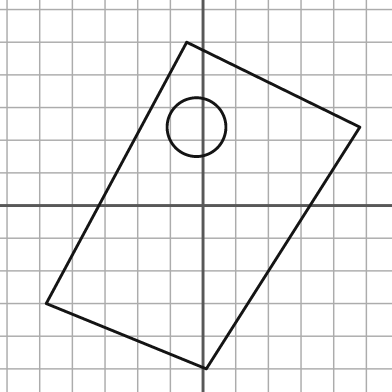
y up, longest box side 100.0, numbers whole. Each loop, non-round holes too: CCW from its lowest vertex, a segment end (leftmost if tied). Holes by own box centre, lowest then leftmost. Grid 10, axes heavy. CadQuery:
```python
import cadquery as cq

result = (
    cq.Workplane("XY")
    .moveTo(1.0, -50.0)
    .lineTo(48.0, 24.0)
    .lineTo(-5.0, 50.0)
    .lineTo(-48.0, -30.0)
    .close()
    .moveTo(-2.0, 24.0)
    .circle(9.0)
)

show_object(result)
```